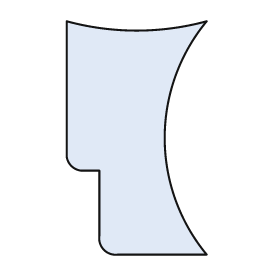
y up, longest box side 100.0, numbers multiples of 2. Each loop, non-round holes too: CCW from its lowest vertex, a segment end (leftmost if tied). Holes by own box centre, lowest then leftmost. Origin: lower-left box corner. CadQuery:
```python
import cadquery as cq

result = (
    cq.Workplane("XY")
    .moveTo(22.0, 0.0)
    .lineTo(60.0, 0.0)
    .threePointArc((42.0, 50.0), (60.0, 100.0))
    .threePointArc((30.0, 96.0), (0.0, 100.0))
    .lineTo(0.0, 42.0)
    .threePointArc((2.0, 38.0), (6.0, 36.0))
    .lineTo(14.0, 36.0)
    .lineTo(14.0, 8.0)
    .threePointArc((16.0, 2.0), (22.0, 0.0))
    .close()
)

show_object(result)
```